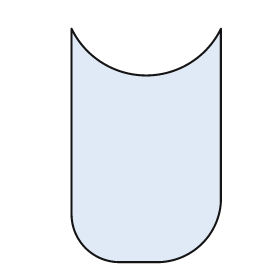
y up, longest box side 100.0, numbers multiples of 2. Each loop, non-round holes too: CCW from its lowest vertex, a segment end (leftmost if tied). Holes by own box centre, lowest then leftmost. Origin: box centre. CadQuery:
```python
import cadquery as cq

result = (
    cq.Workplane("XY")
    .moveTo(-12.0, -50.0)
    .lineTo(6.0, -50.0)
    .threePointArc((24.0, -42.0), (32.0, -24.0))
    .lineTo(32.0, 50.0)
    .threePointArc((0.0, 30.0), (-32.0, 50.0))
    .lineTo(-32.0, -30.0)
    .threePointArc((-26.0, -44.0), (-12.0, -50.0))
    .close()
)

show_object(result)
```